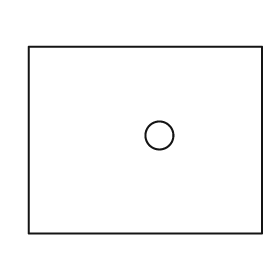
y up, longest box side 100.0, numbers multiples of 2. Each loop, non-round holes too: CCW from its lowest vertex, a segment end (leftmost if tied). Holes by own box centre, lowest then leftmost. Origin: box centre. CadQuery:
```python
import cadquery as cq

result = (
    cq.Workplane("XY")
    .moveTo(-50.0, -40.0)
    .lineTo(50.0, -40.0)
    .lineTo(50.0, 40.0)
    .lineTo(-50.0, 40.0)
    .close()
    .moveTo(6.0, 2.0)
    .circle(6.0)
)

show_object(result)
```